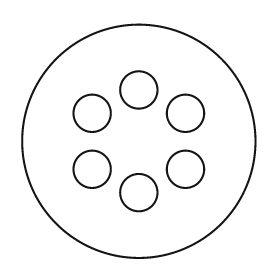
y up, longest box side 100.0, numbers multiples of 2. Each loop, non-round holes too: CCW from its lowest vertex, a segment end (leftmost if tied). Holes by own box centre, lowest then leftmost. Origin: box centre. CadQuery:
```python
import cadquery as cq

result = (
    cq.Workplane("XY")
    .moveTo(0.0, 0.0)
    .circle(50.0)
    .moveTo(0.0, -22.0)
    .circle(8.0)
    .moveTo(-20.0, -12.0)
    .circle(8.0)
    .moveTo(20.0, -12.0)
    .circle(8.0)
    .moveTo(-20.0, 12.0)
    .circle(8.0)
    .moveTo(20.0, 12.0)
    .circle(8.0)
    .moveTo(0.0, 22.0)
    .circle(8.0)
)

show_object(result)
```